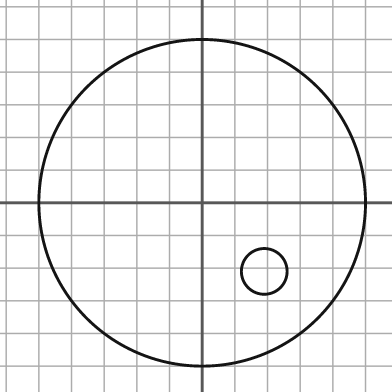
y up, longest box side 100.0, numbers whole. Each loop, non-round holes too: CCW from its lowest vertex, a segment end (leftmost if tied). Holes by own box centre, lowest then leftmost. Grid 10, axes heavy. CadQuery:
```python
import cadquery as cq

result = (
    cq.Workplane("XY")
    .moveTo(0.0, 0.0)
    .circle(50.0)
    .moveTo(19.0, -21.0)
    .circle(7.0)
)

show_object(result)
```